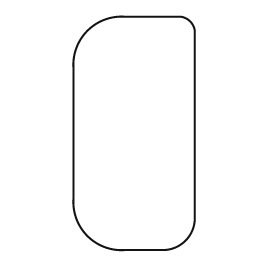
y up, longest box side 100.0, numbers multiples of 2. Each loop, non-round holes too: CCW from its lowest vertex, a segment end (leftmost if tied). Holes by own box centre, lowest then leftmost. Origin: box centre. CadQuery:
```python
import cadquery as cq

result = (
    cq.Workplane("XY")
    .moveTo(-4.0, -50.0)
    .lineTo(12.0, -50.0)
    .threePointArc((22.0, -46.0), (26.0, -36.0))
    .lineTo(26.0, 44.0)
    .threePointArc((24.0, 48.0), (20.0, 50.0))
    .lineTo(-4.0, 50.0)
    .threePointArc((-20.0, 44.0), (-26.0, 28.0))
    .lineTo(-26.0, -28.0)
    .threePointArc((-20.0, -44.0), (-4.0, -50.0))
    .close()
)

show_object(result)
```